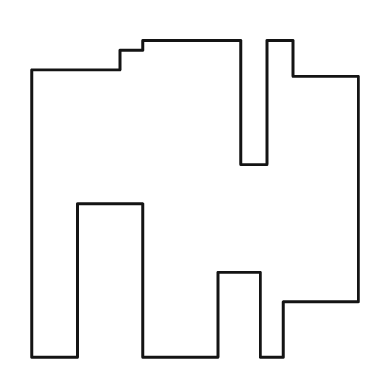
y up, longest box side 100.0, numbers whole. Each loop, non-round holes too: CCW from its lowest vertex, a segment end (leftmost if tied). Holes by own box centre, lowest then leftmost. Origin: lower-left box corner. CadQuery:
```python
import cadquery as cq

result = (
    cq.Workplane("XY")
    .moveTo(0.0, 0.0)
    .lineTo(14.0, 0.0)
    .lineTo(14.0, 47.0)
    .lineTo(34.0, 47.0)
    .lineTo(34.0, 0.0)
    .lineTo(57.0, 0.0)
    .lineTo(57.0, 26.0)
    .lineTo(70.0, 26.0)
    .lineTo(70.0, 0.0)
    .lineTo(77.0, 0.0)
    .lineTo(77.0, 17.0)
    .lineTo(100.0, 17.0)
    .lineTo(100.0, 86.0)
    .lineTo(80.0, 86.0)
    .lineTo(80.0, 97.0)
    .lineTo(72.0, 97.0)
    .lineTo(72.0, 59.0)
    .lineTo(64.0, 59.0)
    .lineTo(64.0, 97.0)
    .lineTo(34.0, 97.0)
    .lineTo(34.0, 94.0)
    .lineTo(27.0, 94.0)
    .lineTo(27.0, 88.0)
    .lineTo(0.0, 88.0)
    .close()
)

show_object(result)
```